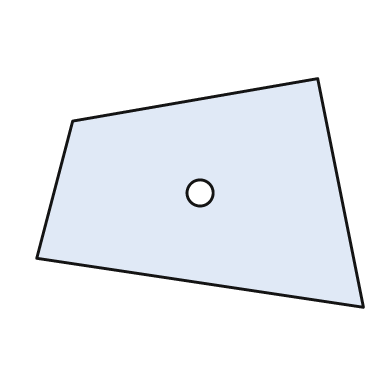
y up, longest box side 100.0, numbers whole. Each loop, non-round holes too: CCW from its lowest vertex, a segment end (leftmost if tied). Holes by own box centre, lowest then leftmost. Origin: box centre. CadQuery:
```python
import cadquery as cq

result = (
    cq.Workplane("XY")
    .moveTo(50.0, -35.0)
    .lineTo(36.0, 35.0)
    .lineTo(-39.0, 22.0)
    .lineTo(-50.0, -20.0)
    .close()
    .moveTo(0.0, 0.0)
    .circle(4.0)
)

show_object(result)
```